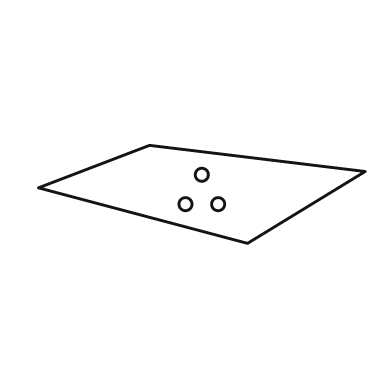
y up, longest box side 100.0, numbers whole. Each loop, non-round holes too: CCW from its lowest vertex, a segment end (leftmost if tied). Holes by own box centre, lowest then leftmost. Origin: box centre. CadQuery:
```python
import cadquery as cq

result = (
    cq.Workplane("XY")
    .moveTo(14.0, -15.0)
    .lineTo(50.0, 7.0)
    .lineTo(-16.0, 15.0)
    .lineTo(-50.0, 2.0)
    .close()
    .moveTo(-5.0, -3.0)
    .circle(2.0)
    .moveTo(5.0, -3.0)
    .circle(2.0)
    .moveTo(0.0, 6.0)
    .circle(2.0)
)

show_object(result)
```